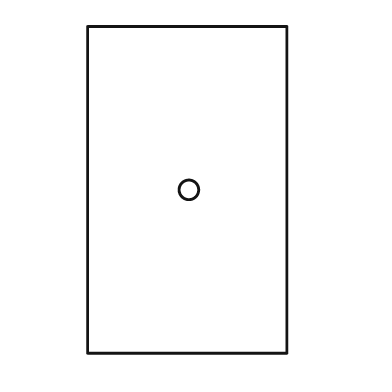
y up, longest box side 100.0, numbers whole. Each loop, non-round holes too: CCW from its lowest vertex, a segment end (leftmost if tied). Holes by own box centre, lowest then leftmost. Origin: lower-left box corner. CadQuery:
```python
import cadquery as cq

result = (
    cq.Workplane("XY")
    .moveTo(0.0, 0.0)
    .lineTo(61.0, 0.0)
    .lineTo(61.0, 100.0)
    .lineTo(0.0, 100.0)
    .close()
    .moveTo(31.0, 50.0)
    .circle(3.0)
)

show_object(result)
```